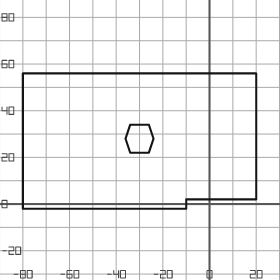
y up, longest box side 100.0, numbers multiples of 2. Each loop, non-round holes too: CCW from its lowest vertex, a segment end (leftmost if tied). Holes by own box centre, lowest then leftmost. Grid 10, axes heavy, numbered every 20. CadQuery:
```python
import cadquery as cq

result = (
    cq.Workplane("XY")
    .moveTo(-80.0, -2.0)
    .lineTo(-10.0, -2.0)
    .lineTo(-10.0, 2.0)
    .lineTo(20.0, 2.0)
    .lineTo(20.0, 56.0)
    .lineTo(-80.0, 56.0)
    .close()
    .moveTo(-34.0, 22.0)
    .lineTo(-26.0, 22.0)
    .lineTo(-24.0, 28.0)
    .lineTo(-26.0, 34.0)
    .lineTo(-34.0, 34.0)
    .lineTo(-36.0, 28.0)
    .close()
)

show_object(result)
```